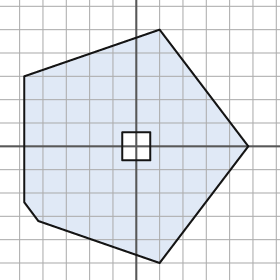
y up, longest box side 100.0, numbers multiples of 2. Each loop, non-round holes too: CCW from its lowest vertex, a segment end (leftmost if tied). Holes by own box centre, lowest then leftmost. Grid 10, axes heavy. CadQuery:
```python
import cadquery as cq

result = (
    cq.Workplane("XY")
    .moveTo(10.0, -50.0)
    .lineTo(48.0, 0.0)
    .lineTo(10.0, 50.0)
    .lineTo(-48.0, 30.0)
    .lineTo(-48.0, -24.0)
    .lineTo(-42.0, -32.0)
    .close()
    .moveTo(-6.0, -6.0)
    .lineTo(6.0, -6.0)
    .lineTo(6.0, 6.0)
    .lineTo(-6.0, 6.0)
    .close()
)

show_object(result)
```